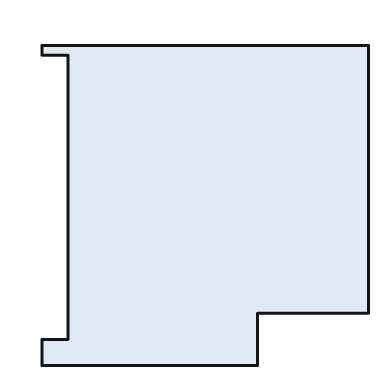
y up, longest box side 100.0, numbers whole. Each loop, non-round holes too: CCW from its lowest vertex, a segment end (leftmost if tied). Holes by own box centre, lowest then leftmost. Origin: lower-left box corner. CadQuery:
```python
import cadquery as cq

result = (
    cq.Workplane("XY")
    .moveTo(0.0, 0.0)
    .lineTo(66.0, 0.0)
    .lineTo(66.0, 16.0)
    .lineTo(100.0, 16.0)
    .lineTo(100.0, 98.0)
    .lineTo(0.0, 98.0)
    .lineTo(0.0, 95.0)
    .lineTo(8.0, 95.0)
    .lineTo(8.0, 8.0)
    .lineTo(0.0, 8.0)
    .close()
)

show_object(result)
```